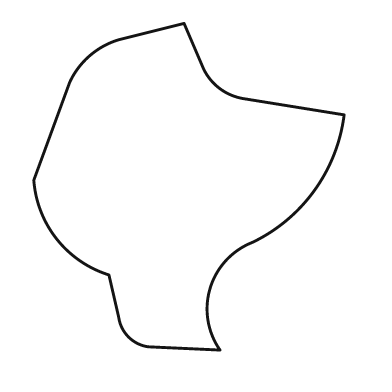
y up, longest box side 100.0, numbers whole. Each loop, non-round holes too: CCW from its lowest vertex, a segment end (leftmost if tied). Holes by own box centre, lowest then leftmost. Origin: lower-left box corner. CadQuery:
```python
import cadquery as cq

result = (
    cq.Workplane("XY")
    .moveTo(57.0, 0.0)
    .threePointArc((54.0, 19.0), (67.0, 33.0))
    .threePointArc((86.0, 49.0), (95.0, 72.0))
    .lineTo(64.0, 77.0)
    .threePointArc((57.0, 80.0), (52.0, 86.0))
    .lineTo(46.0, 100.0)
    .lineTo(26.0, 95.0)
    .threePointArc((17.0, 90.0), (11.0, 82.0))
    .lineTo(0.0, 52.0)
    .threePointArc((7.0, 34.0), (23.0, 23.0))
    .lineTo(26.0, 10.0)
    .threePointArc((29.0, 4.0), (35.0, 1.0))
    .close()
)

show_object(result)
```